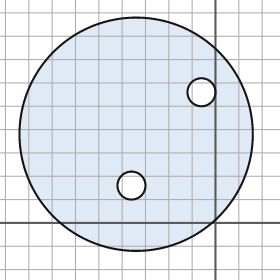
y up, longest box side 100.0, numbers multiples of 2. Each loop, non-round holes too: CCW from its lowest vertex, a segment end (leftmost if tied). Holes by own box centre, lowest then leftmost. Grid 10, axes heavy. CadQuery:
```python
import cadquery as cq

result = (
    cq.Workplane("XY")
    .moveTo(-34.0, 38.0)
    .circle(50.0)
    .moveTo(-36.0, 16.0)
    .circle(6.0)
    .moveTo(-6.0, 56.0)
    .circle(6.0)
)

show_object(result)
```